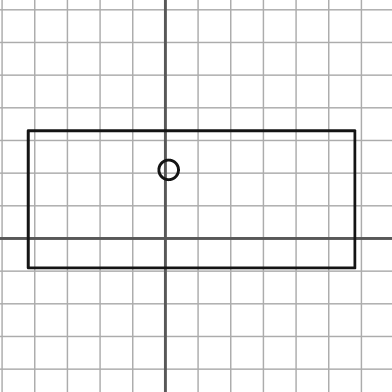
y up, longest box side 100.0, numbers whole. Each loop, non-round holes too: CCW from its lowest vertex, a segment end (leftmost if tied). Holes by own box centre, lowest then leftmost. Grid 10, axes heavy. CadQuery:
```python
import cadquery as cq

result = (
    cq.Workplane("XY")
    .moveTo(-42.0, -9.0)
    .lineTo(58.0, -9.0)
    .lineTo(58.0, 33.0)
    .lineTo(-42.0, 33.0)
    .close()
    .moveTo(1.0, 21.0)
    .circle(3.0)
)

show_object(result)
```